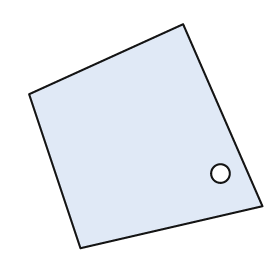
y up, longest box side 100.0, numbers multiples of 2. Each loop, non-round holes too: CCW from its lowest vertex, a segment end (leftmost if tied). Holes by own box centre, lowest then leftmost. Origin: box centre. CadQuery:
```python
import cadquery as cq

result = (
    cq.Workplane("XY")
    .moveTo(-28.0, -48.0)
    .lineTo(50.0, -30.0)
    .lineTo(16.0, 48.0)
    .lineTo(-50.0, 18.0)
    .close()
    .moveTo(32.0, -16.0)
    .circle(4.0)
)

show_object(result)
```